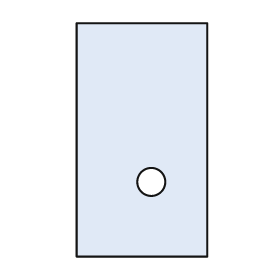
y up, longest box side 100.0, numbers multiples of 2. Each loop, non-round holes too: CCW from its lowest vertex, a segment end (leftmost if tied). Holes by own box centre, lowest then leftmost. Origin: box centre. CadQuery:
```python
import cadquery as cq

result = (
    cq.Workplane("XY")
    .moveTo(-28.0, -50.0)
    .lineTo(28.0, -50.0)
    .lineTo(28.0, 50.0)
    .lineTo(-28.0, 50.0)
    .close()
    .moveTo(4.0, -18.0)
    .circle(6.0)
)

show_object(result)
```